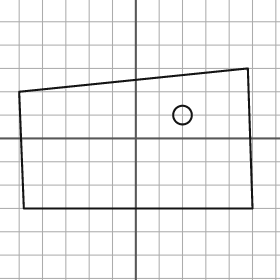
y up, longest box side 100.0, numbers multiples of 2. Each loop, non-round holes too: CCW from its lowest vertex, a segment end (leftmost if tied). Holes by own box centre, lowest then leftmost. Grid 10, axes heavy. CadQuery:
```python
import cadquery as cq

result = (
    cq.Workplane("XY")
    .moveTo(-48.0, -30.0)
    .lineTo(50.0, -30.0)
    .lineTo(48.0, 30.0)
    .lineTo(-50.0, 20.0)
    .close()
    .moveTo(20.0, 10.0)
    .circle(4.0)
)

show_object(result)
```